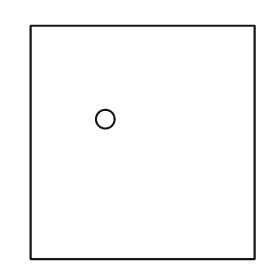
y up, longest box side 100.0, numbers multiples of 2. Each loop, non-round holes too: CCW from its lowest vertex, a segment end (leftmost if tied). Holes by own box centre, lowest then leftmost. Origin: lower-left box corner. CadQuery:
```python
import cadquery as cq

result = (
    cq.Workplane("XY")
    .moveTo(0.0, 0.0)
    .lineTo(96.0, 0.0)
    .lineTo(96.0, 100.0)
    .lineTo(0.0, 100.0)
    .close()
    .moveTo(32.0, 60.0)
    .circle(4.0)
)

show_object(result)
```